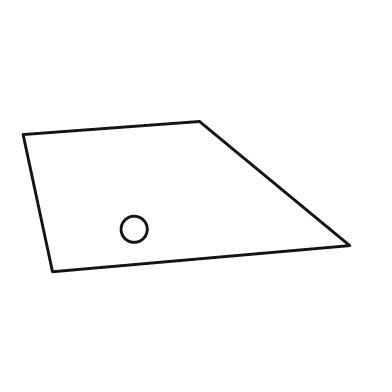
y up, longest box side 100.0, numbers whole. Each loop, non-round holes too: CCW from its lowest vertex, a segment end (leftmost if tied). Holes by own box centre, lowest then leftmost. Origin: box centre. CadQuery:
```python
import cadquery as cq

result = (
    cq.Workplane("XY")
    .moveTo(-41.0, -23.0)
    .lineTo(50.0, -15.0)
    .lineTo(4.0, 23.0)
    .lineTo(-50.0, 19.0)
    .close()
    .moveTo(-16.0, -10.0)
    .circle(4.0)
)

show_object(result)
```